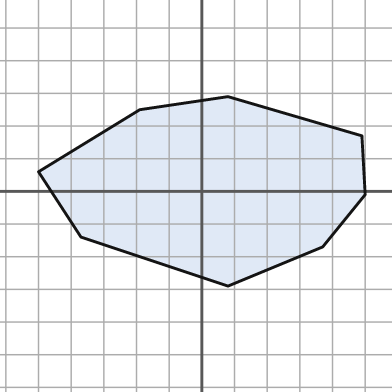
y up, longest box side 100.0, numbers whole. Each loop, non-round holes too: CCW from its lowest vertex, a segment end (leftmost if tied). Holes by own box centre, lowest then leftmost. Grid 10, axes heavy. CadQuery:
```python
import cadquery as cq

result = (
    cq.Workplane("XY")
    .moveTo(8.0, -29.0)
    .lineTo(37.0, -17.0)
    .lineTo(50.0, -1.0)
    .lineTo(49.0, 17.0)
    .lineTo(8.0, 29.0)
    .lineTo(-19.0, 25.0)
    .lineTo(-50.0, 6.0)
    .lineTo(-37.0, -14.0)
    .close()
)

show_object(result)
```